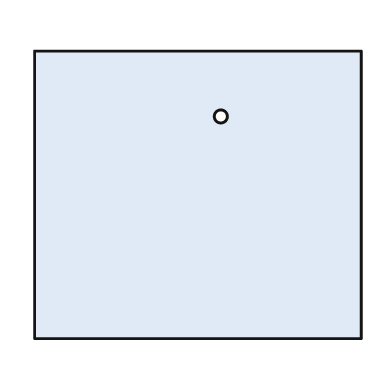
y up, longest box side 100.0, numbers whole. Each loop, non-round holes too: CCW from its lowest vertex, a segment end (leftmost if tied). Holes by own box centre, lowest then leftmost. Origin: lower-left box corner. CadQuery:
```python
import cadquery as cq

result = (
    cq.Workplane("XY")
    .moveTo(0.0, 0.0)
    .lineTo(100.0, 0.0)
    .lineTo(100.0, 88.0)
    .lineTo(0.0, 88.0)
    .close()
    .moveTo(57.0, 68.0)
    .circle(2.0)
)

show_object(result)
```